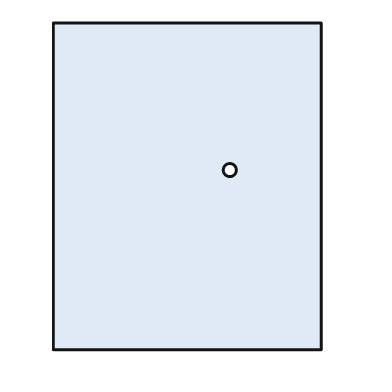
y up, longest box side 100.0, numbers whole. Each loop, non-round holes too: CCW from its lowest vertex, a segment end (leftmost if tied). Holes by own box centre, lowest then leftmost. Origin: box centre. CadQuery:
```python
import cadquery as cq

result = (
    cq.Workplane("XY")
    .moveTo(-41.0, -50.0)
    .lineTo(41.0, -50.0)
    .lineTo(41.0, 50.0)
    .lineTo(-41.0, 50.0)
    .close()
    .moveTo(13.0, 5.0)
    .circle(2.0)
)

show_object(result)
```